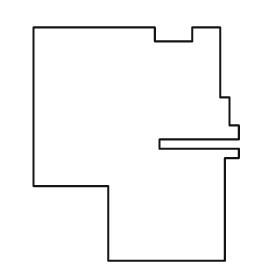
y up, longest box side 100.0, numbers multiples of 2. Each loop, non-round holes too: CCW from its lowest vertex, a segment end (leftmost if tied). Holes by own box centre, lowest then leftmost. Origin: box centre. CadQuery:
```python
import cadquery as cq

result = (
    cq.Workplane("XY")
    .moveTo(-12.0, -50.0)
    .lineTo(38.0, -50.0)
    .lineTo(38.0, -6.0)
    .lineTo(44.0, -6.0)
    .lineTo(44.0, -2.0)
    .lineTo(10.0, -2.0)
    .lineTo(10.0, 2.0)
    .lineTo(44.0, 2.0)
    .lineTo(44.0, 8.0)
    .lineTo(40.0, 8.0)
    .lineTo(40.0, 20.0)
    .lineTo(36.0, 20.0)
    .lineTo(36.0, 50.0)
    .lineTo(24.0, 50.0)
    .lineTo(24.0, 44.0)
    .lineTo(8.0, 44.0)
    .lineTo(8.0, 50.0)
    .lineTo(-44.0, 50.0)
    .lineTo(-44.0, -18.0)
    .lineTo(-12.0, -18.0)
    .close()
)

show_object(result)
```